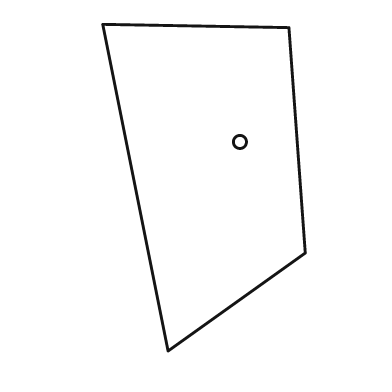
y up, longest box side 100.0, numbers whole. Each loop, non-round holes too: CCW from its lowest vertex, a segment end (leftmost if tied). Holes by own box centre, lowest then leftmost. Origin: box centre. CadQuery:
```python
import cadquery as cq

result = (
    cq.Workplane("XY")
    .moveTo(-11.0, -50.0)
    .lineTo(31.0, -20.0)
    .lineTo(26.0, 49.0)
    .lineTo(-31.0, 50.0)
    .close()
    .moveTo(11.0, 14.0)
    .circle(2.0)
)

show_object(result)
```